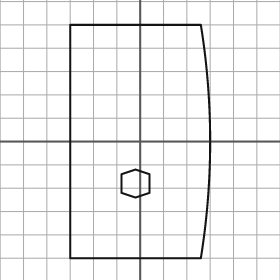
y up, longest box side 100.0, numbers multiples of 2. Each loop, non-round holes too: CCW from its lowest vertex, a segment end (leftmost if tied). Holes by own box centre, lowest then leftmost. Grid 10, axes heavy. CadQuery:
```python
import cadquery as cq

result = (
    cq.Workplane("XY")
    .moveTo(-30.0, -50.0)
    .lineTo(26.0, -50.0)
    .threePointArc((30.0, 0.0), (26.0, 50.0))
    .lineTo(-30.0, 50.0)
    .close()
    .moveTo(-2.0, -24.0)
    .lineTo(4.0, -22.0)
    .lineTo(4.0, -14.0)
    .lineTo(-2.0, -12.0)
    .lineTo(-8.0, -14.0)
    .lineTo(-8.0, -22.0)
    .close()
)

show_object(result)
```